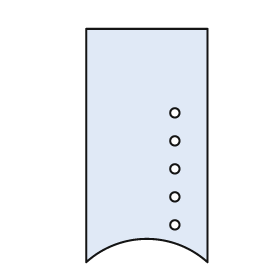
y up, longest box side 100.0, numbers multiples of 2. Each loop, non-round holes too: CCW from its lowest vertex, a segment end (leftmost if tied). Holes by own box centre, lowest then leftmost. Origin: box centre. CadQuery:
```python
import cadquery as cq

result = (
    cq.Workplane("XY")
    .moveTo(-26.0, -50.0)
    .threePointArc((0.0, -40.0), (26.0, -50.0))
    .lineTo(26.0, 50.0)
    .lineTo(-26.0, 50.0)
    .close()
    .moveTo(12.0, -34.0)
    .circle(2.0)
    .moveTo(12.0, -22.0)
    .circle(2.0)
    .moveTo(12.0, -10.0)
    .circle(2.0)
    .moveTo(12.0, 2.0)
    .circle(2.0)
    .moveTo(12.0, 14.0)
    .circle(2.0)
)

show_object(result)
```